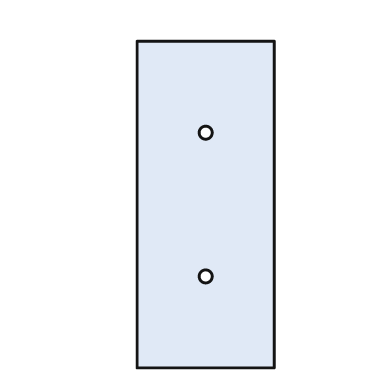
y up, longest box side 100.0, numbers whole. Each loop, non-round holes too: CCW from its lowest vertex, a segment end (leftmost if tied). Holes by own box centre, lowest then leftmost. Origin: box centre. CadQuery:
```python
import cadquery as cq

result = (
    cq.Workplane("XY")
    .moveTo(-21.0, -50.0)
    .lineTo(21.0, -50.0)
    .lineTo(21.0, 50.0)
    .lineTo(-21.0, 50.0)
    .close()
    .moveTo(0.0, -22.0)
    .circle(2.0)
    .moveTo(0.0, 22.0)
    .circle(2.0)
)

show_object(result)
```